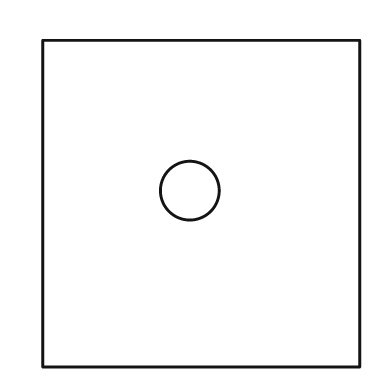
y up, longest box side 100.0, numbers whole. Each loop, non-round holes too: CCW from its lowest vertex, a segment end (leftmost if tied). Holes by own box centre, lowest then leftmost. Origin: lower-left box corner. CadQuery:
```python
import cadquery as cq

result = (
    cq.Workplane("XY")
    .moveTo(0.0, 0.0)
    .lineTo(97.0, 0.0)
    .lineTo(97.0, 100.0)
    .lineTo(0.0, 100.0)
    .close()
    .moveTo(45.0, 54.0)
    .circle(9.0)
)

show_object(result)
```